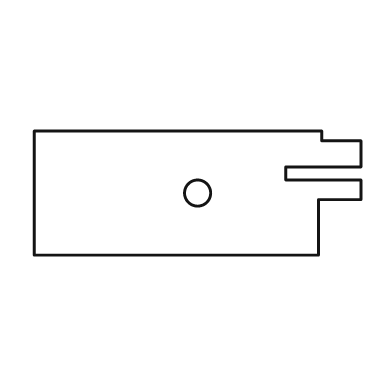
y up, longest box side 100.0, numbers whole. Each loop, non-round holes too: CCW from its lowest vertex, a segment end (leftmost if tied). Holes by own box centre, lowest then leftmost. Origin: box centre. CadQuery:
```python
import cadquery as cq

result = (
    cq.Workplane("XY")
    .moveTo(-50.0, -19.0)
    .lineTo(37.0, -19.0)
    .lineTo(37.0, -2.0)
    .lineTo(50.0, -2.0)
    .lineTo(50.0, 4.0)
    .lineTo(27.0, 4.0)
    .lineTo(27.0, 8.0)
    .lineTo(50.0, 8.0)
    .lineTo(50.0, 16.0)
    .lineTo(38.0, 16.0)
    .lineTo(38.0, 19.0)
    .lineTo(-50.0, 19.0)
    .close()
    .moveTo(0.0, 0.0)
    .circle(4.0)
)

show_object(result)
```